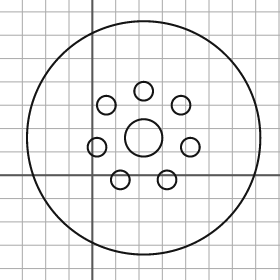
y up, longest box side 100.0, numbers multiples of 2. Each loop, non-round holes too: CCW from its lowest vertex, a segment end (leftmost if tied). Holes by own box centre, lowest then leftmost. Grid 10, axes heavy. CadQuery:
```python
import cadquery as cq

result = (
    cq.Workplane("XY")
    .moveTo(22.0, 16.0)
    .circle(50.0)
    .moveTo(12.0, -2.0)
    .circle(4.0)
    .moveTo(32.0, -2.0)
    .circle(4.0)
    .moveTo(2.0, 12.0)
    .circle(4.0)
    .moveTo(42.0, 12.0)
    .circle(4.0)
    .moveTo(22.0, 16.0)
    .circle(8.0)
    .moveTo(6.0, 30.0)
    .circle(4.0)
    .moveTo(38.0, 30.0)
    .circle(4.0)
    .moveTo(22.0, 36.0)
    .circle(4.0)
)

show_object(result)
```